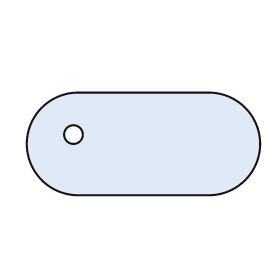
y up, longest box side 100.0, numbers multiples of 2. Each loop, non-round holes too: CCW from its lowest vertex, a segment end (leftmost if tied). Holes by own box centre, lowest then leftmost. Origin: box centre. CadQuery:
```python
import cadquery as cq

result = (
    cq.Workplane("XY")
    .moveTo(-28.0, -22.0)
    .lineTo(28.0, -22.0)
    .threePointArc((50.0, 0.0), (28.0, 22.0))
    .lineTo(-28.0, 22.0)
    .threePointArc((-50.0, 0.0), (-28.0, -22.0))
    .close()
    .moveTo(-30.0, 4.0)
    .circle(4.0)
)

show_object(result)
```